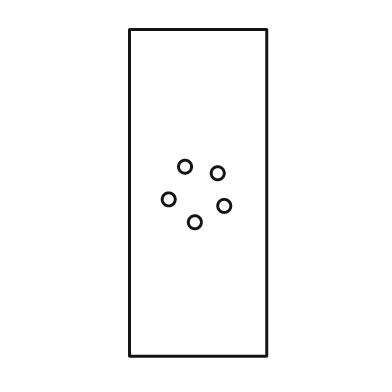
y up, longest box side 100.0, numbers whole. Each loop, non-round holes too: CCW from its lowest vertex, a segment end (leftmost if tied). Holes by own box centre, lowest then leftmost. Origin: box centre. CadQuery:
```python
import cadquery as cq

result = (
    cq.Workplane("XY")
    .moveTo(-21.0, -50.0)
    .lineTo(21.0, -50.0)
    .lineTo(21.0, 50.0)
    .lineTo(-21.0, 50.0)
    .close()
    .moveTo(-1.0, -9.0)
    .circle(2.0)
    .moveTo(8.0, -4.0)
    .circle(2.0)
    .moveTo(-9.0, -2.0)
    .circle(2.0)
    .moveTo(6.0, 6.0)
    .circle(2.0)
    .moveTo(-4.0, 8.0)
    .circle(2.0)
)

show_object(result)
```